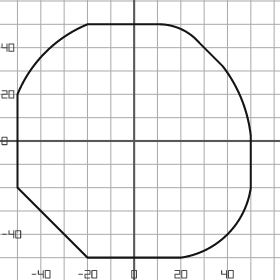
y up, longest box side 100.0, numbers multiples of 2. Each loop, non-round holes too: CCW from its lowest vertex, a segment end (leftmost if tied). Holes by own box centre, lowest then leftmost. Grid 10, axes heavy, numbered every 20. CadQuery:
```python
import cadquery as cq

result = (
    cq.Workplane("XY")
    .moveTo(-20.0, -50.0)
    .lineTo(20.0, -50.0)
    .threePointArc((40.0, -40.0), (50.0, -20.0))
    .lineTo(50.0, 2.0)
    .threePointArc((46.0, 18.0), (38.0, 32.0))
    .lineTo(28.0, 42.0)
    .threePointArc((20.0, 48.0), (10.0, 50.0))
    .lineTo(-20.0, 50.0)
    .threePointArc((-38.0, 38.0), (-50.0, 20.0))
    .lineTo(-50.0, -20.0)
    .close()
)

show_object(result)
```